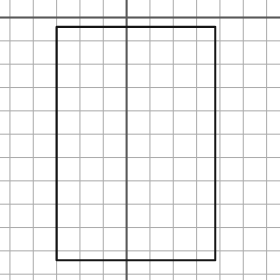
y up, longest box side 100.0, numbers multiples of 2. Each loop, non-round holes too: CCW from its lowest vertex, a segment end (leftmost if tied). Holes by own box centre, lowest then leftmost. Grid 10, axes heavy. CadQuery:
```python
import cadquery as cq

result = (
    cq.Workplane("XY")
    .moveTo(-30.0, -104.0)
    .lineTo(38.0, -104.0)
    .lineTo(38.0, -4.0)
    .lineTo(-30.0, -4.0)
    .close()
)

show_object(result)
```